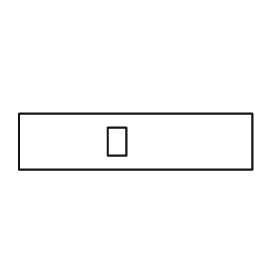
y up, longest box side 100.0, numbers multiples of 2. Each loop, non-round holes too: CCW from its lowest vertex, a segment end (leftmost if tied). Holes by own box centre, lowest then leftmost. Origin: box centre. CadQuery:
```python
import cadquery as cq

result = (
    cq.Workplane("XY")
    .moveTo(-50.0, -12.0)
    .lineTo(50.0, -12.0)
    .lineTo(50.0, 12.0)
    .lineTo(-50.0, 12.0)
    .close()
    .moveTo(-12.0, -6.0)
    .lineTo(-4.0, -6.0)
    .lineTo(-4.0, 6.0)
    .lineTo(-12.0, 6.0)
    .close()
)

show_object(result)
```